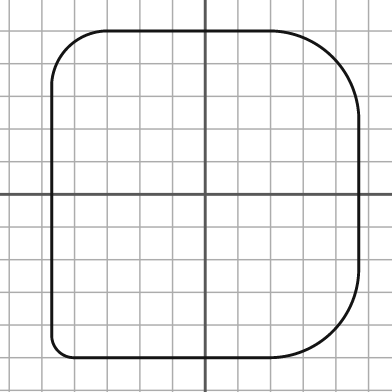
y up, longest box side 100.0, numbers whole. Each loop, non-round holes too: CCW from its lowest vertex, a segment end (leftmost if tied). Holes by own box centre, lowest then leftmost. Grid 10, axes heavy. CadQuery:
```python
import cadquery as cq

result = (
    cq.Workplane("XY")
    .moveTo(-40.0, -50.0)
    .lineTo(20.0, -50.0)
    .threePointArc((39.0, -42.0), (47.0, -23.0))
    .lineTo(47.0, 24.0)
    .threePointArc((39.0, 42.0), (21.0, 50.0))
    .lineTo(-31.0, 50.0)
    .threePointArc((-42.0, 45.0), (-47.0, 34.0))
    .lineTo(-47.0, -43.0)
    .threePointArc((-45.0, -48.0), (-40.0, -50.0))
    .close()
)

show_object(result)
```